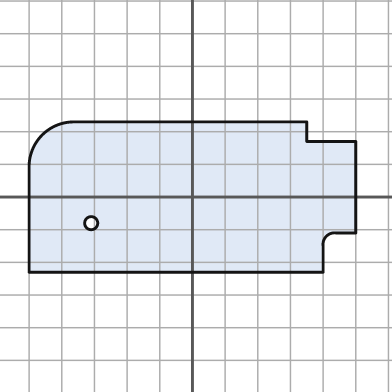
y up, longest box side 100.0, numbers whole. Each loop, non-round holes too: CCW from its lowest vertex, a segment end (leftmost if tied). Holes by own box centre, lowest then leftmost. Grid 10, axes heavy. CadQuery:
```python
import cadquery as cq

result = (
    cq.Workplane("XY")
    .moveTo(-50.0, -23.0)
    .lineTo(40.0, -23.0)
    .lineTo(40.0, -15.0)
    .threePointArc((41.0, -12.0), (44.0, -11.0))
    .lineTo(50.0, -11.0)
    .lineTo(50.0, 17.0)
    .lineTo(35.0, 17.0)
    .lineTo(35.0, 23.0)
    .lineTo(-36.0, 23.0)
    .threePointArc((-46.0, 19.0), (-50.0, 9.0))
    .close()
    .moveTo(-31.0, -8.0)
    .circle(2.0)
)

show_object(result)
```